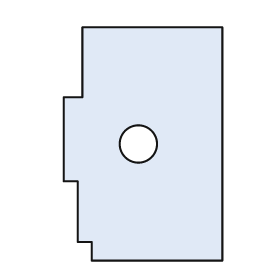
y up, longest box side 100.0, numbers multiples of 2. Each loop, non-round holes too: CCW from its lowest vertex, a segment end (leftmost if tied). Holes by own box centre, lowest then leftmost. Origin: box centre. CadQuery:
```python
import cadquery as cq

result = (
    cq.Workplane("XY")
    .moveTo(-22.0, -50.0)
    .lineTo(34.0, -50.0)
    .lineTo(34.0, 50.0)
    .lineTo(-26.0, 50.0)
    .lineTo(-26.0, 20.0)
    .lineTo(-34.0, 20.0)
    .lineTo(-34.0, -16.0)
    .lineTo(-28.0, -16.0)
    .lineTo(-28.0, -42.0)
    .lineTo(-22.0, -42.0)
    .close()
    .moveTo(-2.0, 0.0)
    .circle(8.0)
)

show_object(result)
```